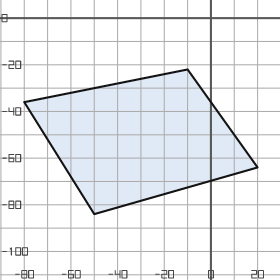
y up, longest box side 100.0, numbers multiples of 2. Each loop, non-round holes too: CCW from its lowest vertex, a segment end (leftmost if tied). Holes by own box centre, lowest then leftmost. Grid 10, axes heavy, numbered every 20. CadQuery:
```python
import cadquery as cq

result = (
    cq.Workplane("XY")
    .moveTo(-50.0, -84.0)
    .lineTo(20.0, -64.0)
    .lineTo(-10.0, -22.0)
    .lineTo(-80.0, -36.0)
    .close()
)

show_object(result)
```